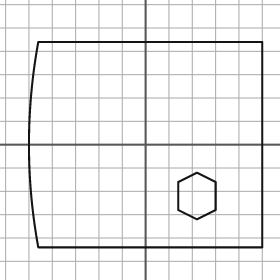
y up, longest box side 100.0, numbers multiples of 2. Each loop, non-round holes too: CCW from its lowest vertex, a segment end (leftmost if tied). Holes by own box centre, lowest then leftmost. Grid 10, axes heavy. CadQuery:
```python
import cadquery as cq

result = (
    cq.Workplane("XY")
    .moveTo(-46.0, -44.0)
    .lineTo(50.0, -44.0)
    .lineTo(50.0, 44.0)
    .lineTo(-46.0, 44.0)
    .threePointArc((-50.0, 0.0), (-46.0, -44.0))
    .close()
    .moveTo(22.0, -32.0)
    .lineTo(30.0, -28.0)
    .lineTo(30.0, -16.0)
    .lineTo(22.0, -12.0)
    .lineTo(14.0, -16.0)
    .lineTo(14.0, -28.0)
    .close()
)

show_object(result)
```